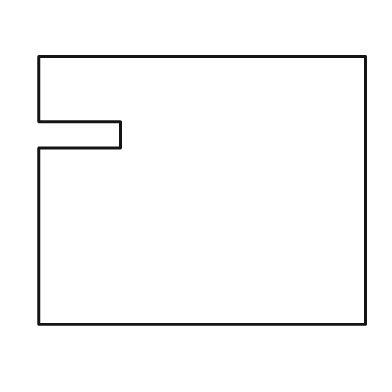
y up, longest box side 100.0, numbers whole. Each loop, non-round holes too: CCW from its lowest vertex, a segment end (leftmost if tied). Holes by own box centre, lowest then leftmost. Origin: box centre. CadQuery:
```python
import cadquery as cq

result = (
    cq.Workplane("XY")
    .moveTo(-50.0, -41.0)
    .lineTo(50.0, -41.0)
    .lineTo(50.0, 41.0)
    .lineTo(-50.0, 41.0)
    .lineTo(-50.0, 21.0)
    .lineTo(-25.0, 21.0)
    .lineTo(-25.0, 13.0)
    .lineTo(-50.0, 13.0)
    .close()
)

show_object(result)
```